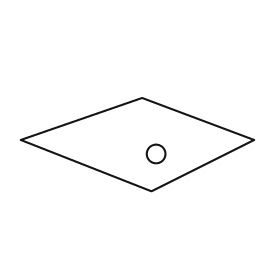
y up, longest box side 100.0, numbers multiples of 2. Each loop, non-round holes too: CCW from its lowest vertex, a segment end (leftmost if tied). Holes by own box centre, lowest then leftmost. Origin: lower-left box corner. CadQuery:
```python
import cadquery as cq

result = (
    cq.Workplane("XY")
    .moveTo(56.0, 0.0)
    .lineTo(100.0, 22.0)
    .lineTo(52.0, 40.0)
    .lineTo(0.0, 22.0)
    .close()
    .moveTo(58.0, 16.0)
    .circle(4.0)
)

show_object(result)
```